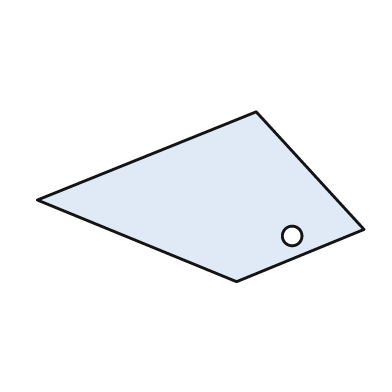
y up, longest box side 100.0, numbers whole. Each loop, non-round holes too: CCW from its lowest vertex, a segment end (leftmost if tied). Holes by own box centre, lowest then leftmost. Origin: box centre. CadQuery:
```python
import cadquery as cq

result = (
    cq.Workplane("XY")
    .moveTo(11.0, -26.0)
    .lineTo(50.0, -10.0)
    .lineTo(17.0, 26.0)
    .lineTo(-50.0, -1.0)
    .close()
    .moveTo(28.0, -12.0)
    .circle(3.0)
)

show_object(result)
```